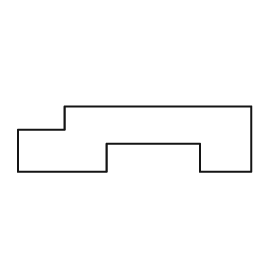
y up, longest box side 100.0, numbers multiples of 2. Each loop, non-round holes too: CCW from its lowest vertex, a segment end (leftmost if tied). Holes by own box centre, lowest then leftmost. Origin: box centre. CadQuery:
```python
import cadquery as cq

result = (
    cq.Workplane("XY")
    .moveTo(-50.0, -14.0)
    .lineTo(-12.0, -14.0)
    .lineTo(-12.0, -2.0)
    .lineTo(28.0, -2.0)
    .lineTo(28.0, -14.0)
    .lineTo(50.0, -14.0)
    .lineTo(50.0, 14.0)
    .lineTo(-30.0, 14.0)
    .lineTo(-30.0, 4.0)
    .lineTo(-50.0, 4.0)
    .close()
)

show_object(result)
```